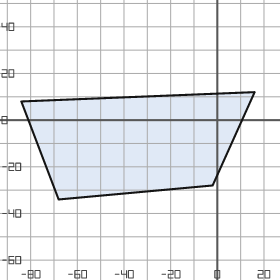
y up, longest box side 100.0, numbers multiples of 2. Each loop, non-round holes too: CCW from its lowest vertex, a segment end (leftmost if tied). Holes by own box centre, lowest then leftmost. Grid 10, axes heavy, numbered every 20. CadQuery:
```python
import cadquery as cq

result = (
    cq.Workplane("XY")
    .moveTo(-68.0, -34.0)
    .lineTo(-2.0, -28.0)
    .lineTo(16.0, 12.0)
    .lineTo(-84.0, 8.0)
    .close()
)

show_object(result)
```